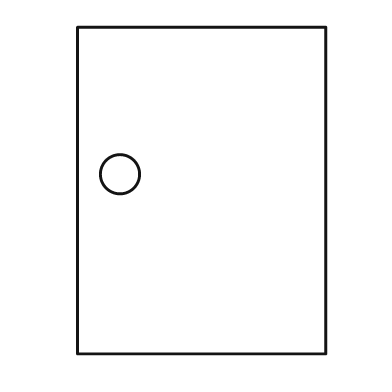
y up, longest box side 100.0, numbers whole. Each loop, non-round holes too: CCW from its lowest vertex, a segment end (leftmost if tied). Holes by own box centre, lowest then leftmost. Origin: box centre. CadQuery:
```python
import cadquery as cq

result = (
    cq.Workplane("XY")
    .moveTo(-38.0, -50.0)
    .lineTo(38.0, -50.0)
    .lineTo(38.0, 50.0)
    .lineTo(-38.0, 50.0)
    .close()
    .moveTo(-25.0, 5.0)
    .circle(6.0)
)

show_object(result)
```